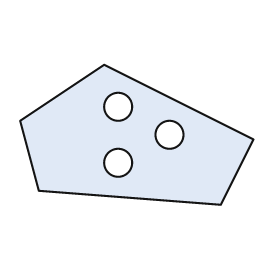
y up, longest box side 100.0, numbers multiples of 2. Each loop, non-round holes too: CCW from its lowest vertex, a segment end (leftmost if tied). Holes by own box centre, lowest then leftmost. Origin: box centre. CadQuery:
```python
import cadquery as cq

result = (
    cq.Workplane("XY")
    .moveTo(36.0, -30.0)
    .lineTo(50.0, -2.0)
    .lineTo(-14.0, 30.0)
    .lineTo(-50.0, 6.0)
    .lineTo(-42.0, -24.0)
    .close()
    .moveTo(-8.0, -12.0)
    .circle(6.0)
    .moveTo(14.0, 0.0)
    .circle(6.0)
    .moveTo(-8.0, 12.0)
    .circle(6.0)
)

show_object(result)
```